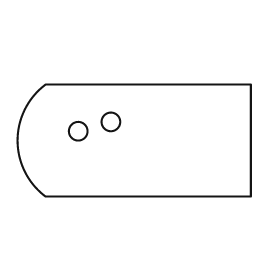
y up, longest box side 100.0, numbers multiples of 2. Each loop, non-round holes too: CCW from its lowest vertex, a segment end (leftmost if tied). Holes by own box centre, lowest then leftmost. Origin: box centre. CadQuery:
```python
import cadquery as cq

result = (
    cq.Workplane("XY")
    .moveTo(-38.0, -24.0)
    .lineTo(50.0, -24.0)
    .lineTo(50.0, 24.0)
    .lineTo(-38.0, 24.0)
    .threePointArc((-50.0, 0.0), (-38.0, -24.0))
    .close()
    .moveTo(-24.0, 4.0)
    .circle(4.0)
    .moveTo(-10.0, 8.0)
    .circle(4.0)
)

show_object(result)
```